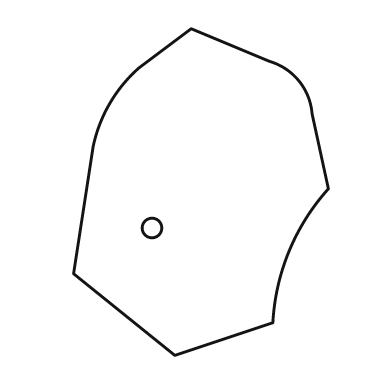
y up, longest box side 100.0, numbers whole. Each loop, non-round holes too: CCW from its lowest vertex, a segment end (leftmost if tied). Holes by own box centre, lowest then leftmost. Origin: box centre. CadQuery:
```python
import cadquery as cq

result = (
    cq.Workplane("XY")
    .moveTo(-8.0, -50.0)
    .lineTo(22.0, -40.0)
    .threePointArc((27.0, -18.0), (39.0, 1.0))
    .lineTo(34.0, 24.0)
    .threePointArc((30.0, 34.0), (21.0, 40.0))
    .lineTo(-3.0, 50.0)
    .lineTo(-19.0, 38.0)
    .threePointArc((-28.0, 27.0), (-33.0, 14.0))
    .lineTo(-39.0, -25.0)
    .close()
    .moveTo(-15.0, -11.0)
    .circle(3.0)
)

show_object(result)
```